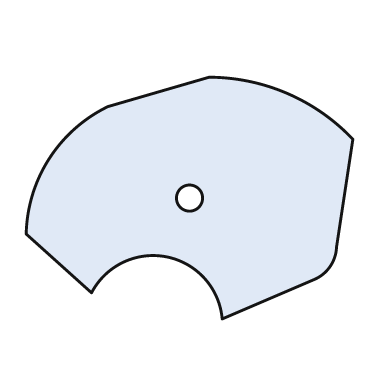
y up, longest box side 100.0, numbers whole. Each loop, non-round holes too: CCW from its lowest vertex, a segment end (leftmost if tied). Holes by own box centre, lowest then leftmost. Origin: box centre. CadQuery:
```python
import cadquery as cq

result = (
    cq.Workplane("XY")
    .moveTo(10.0, -37.0)
    .lineTo(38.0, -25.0)
    .threePointArc((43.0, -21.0), (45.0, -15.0))
    .lineTo(50.0, 18.0)
    .threePointArc((30.0, 32.0), (6.0, 37.0))
    .lineTo(-25.0, 28.0)
    .threePointArc((-43.0, 12.0), (-50.0, -11.0))
    .lineTo(-30.0, -29.0)
    .threePointArc((-7.0, -18.0), (10.0, -37.0))
    .close()
    .moveTo(0.0, 0.0)
    .circle(4.0)
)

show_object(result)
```